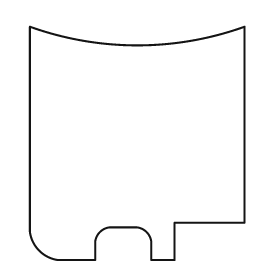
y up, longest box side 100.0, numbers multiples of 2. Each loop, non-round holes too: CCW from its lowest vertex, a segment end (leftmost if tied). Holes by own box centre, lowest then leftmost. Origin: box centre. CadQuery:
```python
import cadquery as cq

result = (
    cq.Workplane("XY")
    .moveTo(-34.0, -50.0)
    .lineTo(-18.0, -50.0)
    .lineTo(-18.0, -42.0)
    .threePointArc((-16.0, -38.0), (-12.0, -36.0))
    .lineTo(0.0, -36.0)
    .threePointArc((4.0, -38.0), (6.0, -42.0))
    .lineTo(6.0, -50.0)
    .lineTo(16.0, -50.0)
    .lineTo(16.0, -34.0)
    .lineTo(46.0, -34.0)
    .lineTo(46.0, 50.0)
    .threePointArc((0.0, 42.0), (-46.0, 50.0))
    .lineTo(-46.0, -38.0)
    .threePointArc((-42.0, -46.0), (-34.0, -50.0))
    .close()
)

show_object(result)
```